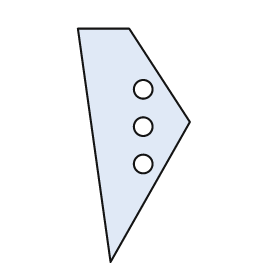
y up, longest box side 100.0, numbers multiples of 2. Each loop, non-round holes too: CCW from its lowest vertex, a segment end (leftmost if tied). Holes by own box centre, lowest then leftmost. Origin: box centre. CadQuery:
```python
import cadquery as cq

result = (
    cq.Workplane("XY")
    .moveTo(-10.0, -50.0)
    .lineTo(24.0, 10.0)
    .lineTo(-2.0, 50.0)
    .lineTo(-24.0, 50.0)
    .close()
    .moveTo(4.0, -8.0)
    .circle(4.0)
    .moveTo(4.0, 8.0)
    .circle(4.0)
    .moveTo(4.0, 24.0)
    .circle(4.0)
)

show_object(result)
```